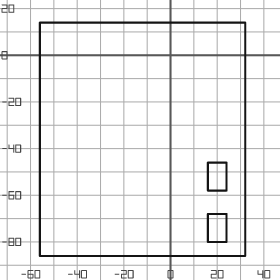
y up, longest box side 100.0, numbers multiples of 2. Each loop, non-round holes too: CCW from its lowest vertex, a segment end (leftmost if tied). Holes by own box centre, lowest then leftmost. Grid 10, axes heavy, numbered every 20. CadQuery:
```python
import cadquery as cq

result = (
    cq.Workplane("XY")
    .moveTo(-56.0, -86.0)
    .lineTo(32.0, -86.0)
    .lineTo(32.0, 14.0)
    .lineTo(-56.0, 14.0)
    .close()
    .moveTo(16.0, -80.0)
    .lineTo(24.0, -80.0)
    .lineTo(24.0, -68.0)
    .lineTo(16.0, -68.0)
    .close()
    .moveTo(16.0, -58.0)
    .lineTo(24.0, -58.0)
    .lineTo(24.0, -46.0)
    .lineTo(16.0, -46.0)
    .close()
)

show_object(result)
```